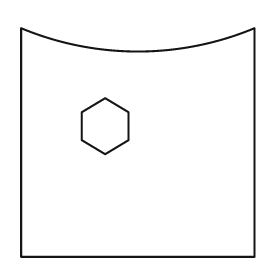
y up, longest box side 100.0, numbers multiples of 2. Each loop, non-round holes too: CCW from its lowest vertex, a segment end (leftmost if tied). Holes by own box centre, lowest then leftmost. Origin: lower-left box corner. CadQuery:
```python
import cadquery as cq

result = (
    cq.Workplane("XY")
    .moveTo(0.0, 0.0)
    .lineTo(100.0, 0.0)
    .lineTo(100.0, 98.0)
    .threePointArc((50.0, 88.0), (0.0, 98.0))
    .close()
    .moveTo(36.0, 44.0)
    .lineTo(46.0, 50.0)
    .lineTo(46.0, 62.0)
    .lineTo(36.0, 68.0)
    .lineTo(26.0, 62.0)
    .lineTo(26.0, 50.0)
    .close()
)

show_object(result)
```